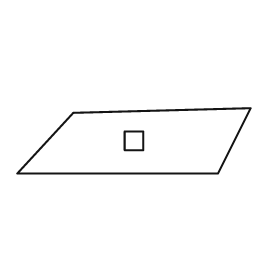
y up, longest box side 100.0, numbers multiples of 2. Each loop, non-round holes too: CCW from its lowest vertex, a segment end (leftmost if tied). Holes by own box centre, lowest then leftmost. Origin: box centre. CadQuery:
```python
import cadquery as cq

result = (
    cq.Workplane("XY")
    .moveTo(-50.0, -14.0)
    .lineTo(36.0, -14.0)
    .lineTo(50.0, 14.0)
    .lineTo(-26.0, 12.0)
    .close()
    .moveTo(-4.0, -4.0)
    .lineTo(4.0, -4.0)
    .lineTo(4.0, 4.0)
    .lineTo(-4.0, 4.0)
    .close()
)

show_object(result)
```